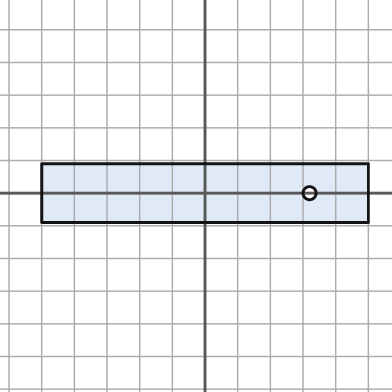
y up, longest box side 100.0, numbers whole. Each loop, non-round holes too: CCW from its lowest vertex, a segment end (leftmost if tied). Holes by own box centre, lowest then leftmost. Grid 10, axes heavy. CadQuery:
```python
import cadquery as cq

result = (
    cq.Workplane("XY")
    .moveTo(-50.0, -9.0)
    .lineTo(50.0, -9.0)
    .lineTo(50.0, 9.0)
    .lineTo(-50.0, 9.0)
    .close()
    .moveTo(32.0, 0.0)
    .circle(2.0)
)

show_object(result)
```